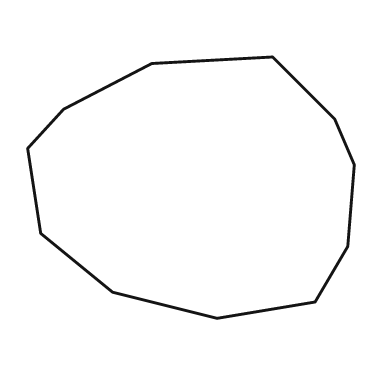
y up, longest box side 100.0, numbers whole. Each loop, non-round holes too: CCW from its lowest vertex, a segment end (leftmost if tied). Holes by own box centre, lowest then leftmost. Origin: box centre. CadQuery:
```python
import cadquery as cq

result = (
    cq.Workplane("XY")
    .moveTo(8.0, -40.0)
    .lineTo(38.0, -35.0)
    .lineTo(48.0, -18.0)
    .lineTo(50.0, 7.0)
    .lineTo(44.0, 21.0)
    .lineTo(25.0, 40.0)
    .lineTo(-12.0, 38.0)
    .lineTo(-39.0, 24.0)
    .lineTo(-50.0, 12.0)
    .lineTo(-46.0, -14.0)
    .lineTo(-24.0, -32.0)
    .close()
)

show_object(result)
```